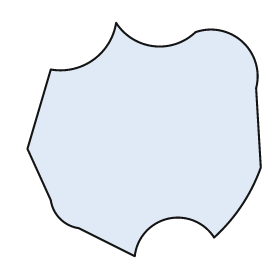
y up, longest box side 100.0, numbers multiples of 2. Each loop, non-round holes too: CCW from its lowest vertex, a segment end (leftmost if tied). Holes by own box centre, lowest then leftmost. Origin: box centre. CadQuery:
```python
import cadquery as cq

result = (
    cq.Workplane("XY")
    .moveTo(-4.0, -50.0)
    .threePointArc((10.0, -34.0), (30.0, -42.0))
    .threePointArc((42.0, -28.0), (50.0, -12.0))
    .lineTo(48.0, 22.0)
    .threePointArc((42.0, 42.0), (22.0, 46.0))
    .threePointArc((4.0, 40.0), (-12.0, 50.0))
    .threePointArc((-22.0, 34.0), (-40.0, 30.0))
    .lineTo(-50.0, -4.0)
    .lineTo(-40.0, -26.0)
    .threePointArc((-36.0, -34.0), (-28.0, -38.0))
    .close()
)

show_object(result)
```